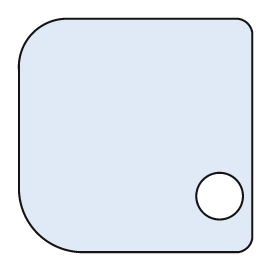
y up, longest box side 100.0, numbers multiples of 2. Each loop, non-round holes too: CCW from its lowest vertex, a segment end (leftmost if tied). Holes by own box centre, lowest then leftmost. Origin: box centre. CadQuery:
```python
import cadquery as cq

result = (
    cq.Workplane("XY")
    .moveTo(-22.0, -50.0)
    .lineTo(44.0, -50.0)
    .threePointArc((48.0, -48.0), (50.0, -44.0))
    .lineTo(50.0, 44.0)
    .threePointArc((48.0, 48.0), (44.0, 50.0))
    .lineTo(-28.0, 50.0)
    .threePointArc((-44.0, 44.0), (-50.0, 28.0))
    .lineTo(-50.0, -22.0)
    .threePointArc((-42.0, -42.0), (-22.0, -50.0))
    .close()
    .moveTo(36.0, -26.0)
    .circle(10.0)
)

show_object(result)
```